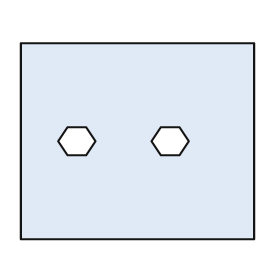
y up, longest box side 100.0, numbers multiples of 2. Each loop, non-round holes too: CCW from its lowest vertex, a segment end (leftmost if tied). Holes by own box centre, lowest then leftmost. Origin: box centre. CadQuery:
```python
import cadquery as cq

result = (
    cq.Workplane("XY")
    .moveTo(-50.0, -42.0)
    .lineTo(50.0, -42.0)
    .lineTo(50.0, 42.0)
    .lineTo(-50.0, 42.0)
    .close()
    .moveTo(-30.0, -6.0)
    .lineTo(-22.0, -6.0)
    .lineTo(-18.0, 0.0)
    .lineTo(-22.0, 6.0)
    .lineTo(-30.0, 6.0)
    .lineTo(-34.0, 0.0)
    .close()
    .moveTo(10.0, -6.0)
    .lineTo(18.0, -6.0)
    .lineTo(22.0, 0.0)
    .lineTo(18.0, 6.0)
    .lineTo(10.0, 6.0)
    .lineTo(6.0, 0.0)
    .close()
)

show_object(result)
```